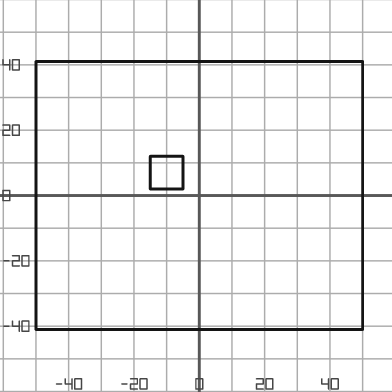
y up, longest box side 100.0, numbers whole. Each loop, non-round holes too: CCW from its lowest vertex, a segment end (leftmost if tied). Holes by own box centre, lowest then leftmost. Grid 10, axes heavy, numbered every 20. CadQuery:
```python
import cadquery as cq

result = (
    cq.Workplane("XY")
    .moveTo(-50.0, -41.0)
    .lineTo(50.0, -41.0)
    .lineTo(50.0, 41.0)
    .lineTo(-50.0, 41.0)
    .close()
    .moveTo(-15.0, 2.0)
    .lineTo(-5.0, 2.0)
    .lineTo(-5.0, 12.0)
    .lineTo(-15.0, 12.0)
    .close()
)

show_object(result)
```